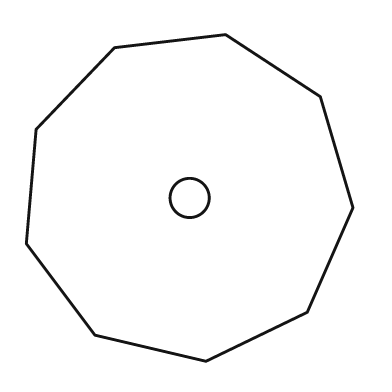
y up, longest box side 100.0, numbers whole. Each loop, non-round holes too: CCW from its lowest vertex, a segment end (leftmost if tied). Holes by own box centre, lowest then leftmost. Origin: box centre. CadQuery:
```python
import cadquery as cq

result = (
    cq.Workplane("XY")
    .moveTo(5.0, -50.0)
    .lineTo(36.0, -35.0)
    .lineTo(50.0, -3.0)
    .lineTo(40.0, 31.0)
    .lineTo(11.0, 50.0)
    .lineTo(-23.0, 46.0)
    .lineTo(-47.0, 21.0)
    .lineTo(-50.0, -14.0)
    .lineTo(-29.0, -42.0)
    .close()
    .moveTo(0.0, 0.0)
    .circle(6.0)
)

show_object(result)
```